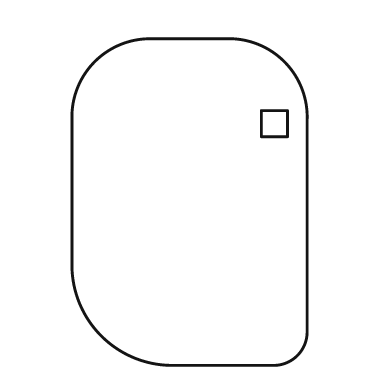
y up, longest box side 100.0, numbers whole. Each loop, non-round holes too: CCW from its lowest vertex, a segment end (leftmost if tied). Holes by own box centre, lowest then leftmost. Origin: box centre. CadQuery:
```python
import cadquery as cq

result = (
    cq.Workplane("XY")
    .moveTo(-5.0, -50.0)
    .lineTo(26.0, -50.0)
    .threePointArc((33.0, -47.0), (36.0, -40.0))
    .lineTo(36.0, 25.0)
    .threePointArc((29.0, 43.0), (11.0, 50.0))
    .lineTo(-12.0, 50.0)
    .threePointArc((-29.0, 43.0), (-36.0, 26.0))
    .lineTo(-36.0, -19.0)
    .threePointArc((-27.0, -41.0), (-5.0, -50.0))
    .close()
    .moveTo(22.0, 20.0)
    .lineTo(30.0, 20.0)
    .lineTo(30.0, 28.0)
    .lineTo(22.0, 28.0)
    .close()
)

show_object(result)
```